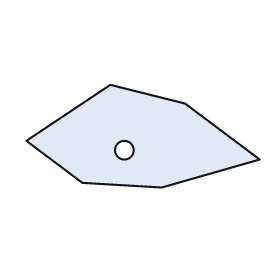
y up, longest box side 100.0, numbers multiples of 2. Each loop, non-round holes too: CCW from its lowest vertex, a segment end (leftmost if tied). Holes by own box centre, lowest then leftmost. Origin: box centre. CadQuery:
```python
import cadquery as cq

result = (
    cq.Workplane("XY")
    .moveTo(8.0, -22.0)
    .lineTo(50.0, -10.0)
    .lineTo(18.0, 14.0)
    .lineTo(-14.0, 22.0)
    .lineTo(-50.0, -2.0)
    .lineTo(-26.0, -20.0)
    .close()
    .moveTo(-8.0, -6.0)
    .circle(4.0)
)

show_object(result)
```